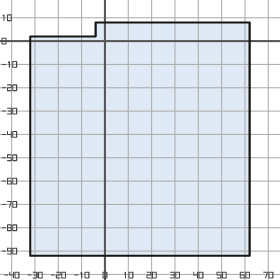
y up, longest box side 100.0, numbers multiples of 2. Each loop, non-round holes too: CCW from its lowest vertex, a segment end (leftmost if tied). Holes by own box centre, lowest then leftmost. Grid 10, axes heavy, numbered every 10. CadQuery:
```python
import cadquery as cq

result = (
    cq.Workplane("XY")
    .moveTo(-32.0, -92.0)
    .lineTo(62.0, -92.0)
    .lineTo(62.0, 8.0)
    .lineTo(-4.0, 8.0)
    .lineTo(-4.0, 2.0)
    .lineTo(-32.0, 2.0)
    .close()
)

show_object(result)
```